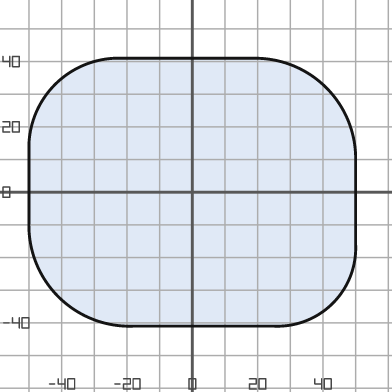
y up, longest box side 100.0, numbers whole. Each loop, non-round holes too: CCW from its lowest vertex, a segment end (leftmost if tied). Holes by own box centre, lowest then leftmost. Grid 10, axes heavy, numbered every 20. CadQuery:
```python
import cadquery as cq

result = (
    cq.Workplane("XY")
    .moveTo(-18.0, -41.0)
    .lineTo(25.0, -41.0)
    .threePointArc((43.0, -34.0), (50.0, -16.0))
    .lineTo(50.0, 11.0)
    .threePointArc((41.0, 32.0), (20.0, 41.0))
    .lineTo(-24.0, 41.0)
    .threePointArc((-42.0, 33.0), (-50.0, 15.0))
    .lineTo(-50.0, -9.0)
    .threePointArc((-41.0, -32.0), (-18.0, -41.0))
    .close()
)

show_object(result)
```